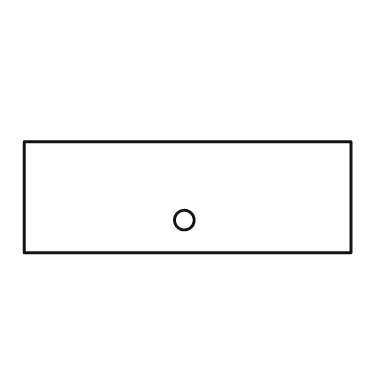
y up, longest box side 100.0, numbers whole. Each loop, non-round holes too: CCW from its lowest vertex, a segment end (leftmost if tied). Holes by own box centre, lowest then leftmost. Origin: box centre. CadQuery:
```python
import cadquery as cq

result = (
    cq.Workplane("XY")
    .moveTo(-50.0, -17.0)
    .lineTo(50.0, -17.0)
    .lineTo(50.0, 17.0)
    .lineTo(-50.0, 17.0)
    .close()
    .moveTo(-1.0, -7.0)
    .circle(3.0)
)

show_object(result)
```